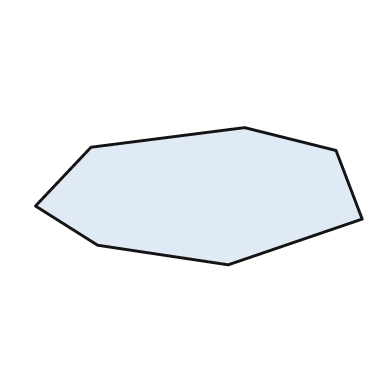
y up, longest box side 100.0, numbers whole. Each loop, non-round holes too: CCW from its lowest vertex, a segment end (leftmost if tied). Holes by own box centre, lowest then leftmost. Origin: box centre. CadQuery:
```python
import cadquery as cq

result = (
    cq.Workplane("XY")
    .moveTo(9.0, -21.0)
    .lineTo(50.0, -7.0)
    .lineTo(42.0, 14.0)
    .lineTo(14.0, 21.0)
    .lineTo(-33.0, 15.0)
    .lineTo(-50.0, -3.0)
    .lineTo(-31.0, -15.0)
    .close()
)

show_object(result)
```